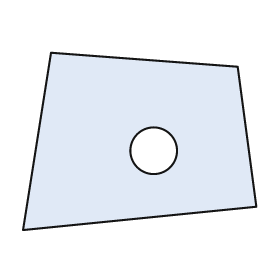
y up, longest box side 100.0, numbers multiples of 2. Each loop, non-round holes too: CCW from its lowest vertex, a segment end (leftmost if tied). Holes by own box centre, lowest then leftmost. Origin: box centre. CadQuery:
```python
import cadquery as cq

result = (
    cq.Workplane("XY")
    .moveTo(-50.0, -38.0)
    .lineTo(50.0, -28.0)
    .lineTo(42.0, 32.0)
    .lineTo(-38.0, 38.0)
    .close()
    .moveTo(6.0, -4.0)
    .circle(10.0)
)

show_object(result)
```